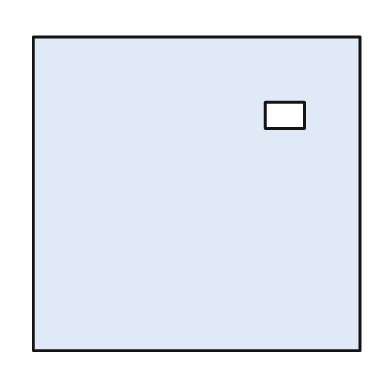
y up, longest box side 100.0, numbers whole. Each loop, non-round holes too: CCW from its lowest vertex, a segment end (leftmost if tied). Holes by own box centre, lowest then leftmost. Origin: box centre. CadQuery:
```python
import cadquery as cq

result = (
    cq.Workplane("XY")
    .moveTo(-50.0, -48.0)
    .lineTo(50.0, -48.0)
    .lineTo(50.0, 48.0)
    .lineTo(-50.0, 48.0)
    .close()
    .moveTo(21.0, 20.0)
    .lineTo(33.0, 20.0)
    .lineTo(33.0, 28.0)
    .lineTo(21.0, 28.0)
    .close()
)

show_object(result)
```